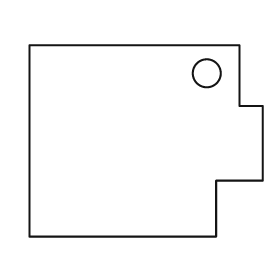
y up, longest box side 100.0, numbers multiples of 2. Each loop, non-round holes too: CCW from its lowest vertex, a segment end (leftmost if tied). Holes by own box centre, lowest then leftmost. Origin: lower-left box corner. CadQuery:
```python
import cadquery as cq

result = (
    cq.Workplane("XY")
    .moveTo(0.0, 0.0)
    .lineTo(80.0, 0.0)
    .lineTo(80.0, 24.0)
    .lineTo(100.0, 24.0)
    .lineTo(100.0, 56.0)
    .lineTo(90.0, 56.0)
    .lineTo(90.0, 82.0)
    .lineTo(0.0, 82.0)
    .close()
    .moveTo(76.0, 70.0)
    .circle(6.0)
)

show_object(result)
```